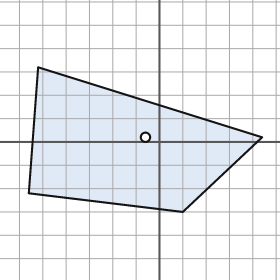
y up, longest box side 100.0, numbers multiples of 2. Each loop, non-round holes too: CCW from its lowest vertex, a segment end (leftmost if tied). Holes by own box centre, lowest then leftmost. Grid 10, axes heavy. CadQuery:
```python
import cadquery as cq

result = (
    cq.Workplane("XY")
    .moveTo(10.0, -30.0)
    .lineTo(44.0, 2.0)
    .lineTo(-52.0, 32.0)
    .lineTo(-56.0, -22.0)
    .close()
    .moveTo(-6.0, 2.0)
    .circle(2.0)
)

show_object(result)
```